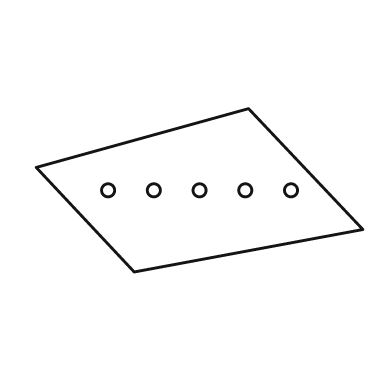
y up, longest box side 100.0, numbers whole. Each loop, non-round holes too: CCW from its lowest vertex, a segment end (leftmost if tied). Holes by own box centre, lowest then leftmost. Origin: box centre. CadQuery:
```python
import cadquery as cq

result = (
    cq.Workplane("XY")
    .moveTo(-20.0, -25.0)
    .lineTo(50.0, -12.0)
    .lineTo(15.0, 25.0)
    .lineTo(-50.0, 7.0)
    .close()
    .moveTo(-28.0, 0.0)
    .circle(2.0)
    .moveTo(-14.0, 0.0)
    .circle(2.0)
    .moveTo(0.0, 0.0)
    .circle(2.0)
    .moveTo(14.0, 0.0)
    .circle(2.0)
    .moveTo(28.0, 0.0)
    .circle(2.0)
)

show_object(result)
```